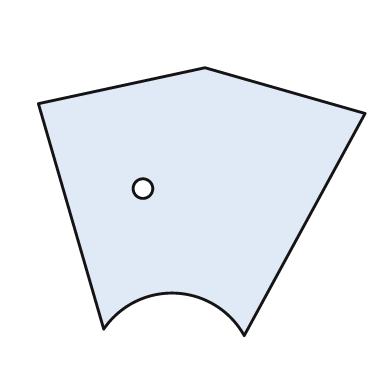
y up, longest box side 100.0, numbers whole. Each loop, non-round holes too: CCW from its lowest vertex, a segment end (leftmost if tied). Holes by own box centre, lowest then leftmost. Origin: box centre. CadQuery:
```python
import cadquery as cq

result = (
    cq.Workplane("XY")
    .moveTo(13.0, -41.0)
    .lineTo(50.0, 27.0)
    .lineTo(1.0, 41.0)
    .lineTo(-50.0, 30.0)
    .lineTo(-30.0, -39.0)
    .threePointArc((-8.0, -28.0), (13.0, -41.0))
    .close()
    .moveTo(-18.0, 4.0)
    .circle(3.0)
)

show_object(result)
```